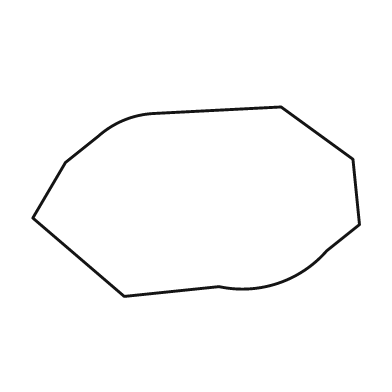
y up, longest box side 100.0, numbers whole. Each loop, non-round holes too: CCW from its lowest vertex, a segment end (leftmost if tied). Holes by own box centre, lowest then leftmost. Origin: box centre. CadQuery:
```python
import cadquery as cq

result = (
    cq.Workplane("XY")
    .moveTo(-22.0, -29.0)
    .lineTo(7.0, -26.0)
    .threePointArc((25.0, -25.0), (40.0, -15.0))
    .lineTo(50.0, -7.0)
    .lineTo(48.0, 13.0)
    .lineTo(26.0, 29.0)
    .lineTo(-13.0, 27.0)
    .threePointArc((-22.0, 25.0), (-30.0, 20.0))
    .lineTo(-40.0, 12.0)
    .lineTo(-50.0, -5.0)
    .close()
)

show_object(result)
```